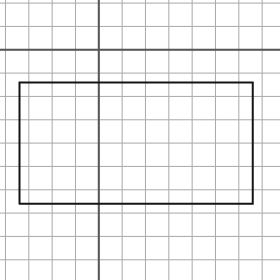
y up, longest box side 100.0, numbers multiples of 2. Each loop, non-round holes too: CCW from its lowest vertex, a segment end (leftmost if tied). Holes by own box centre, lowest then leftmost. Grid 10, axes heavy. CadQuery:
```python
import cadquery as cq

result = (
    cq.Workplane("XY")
    .moveTo(-34.0, -66.0)
    .lineTo(66.0, -66.0)
    .lineTo(66.0, -14.0)
    .lineTo(-34.0, -14.0)
    .close()
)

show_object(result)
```